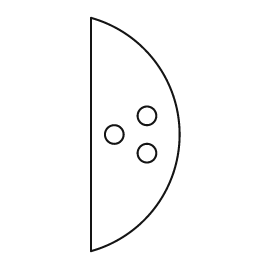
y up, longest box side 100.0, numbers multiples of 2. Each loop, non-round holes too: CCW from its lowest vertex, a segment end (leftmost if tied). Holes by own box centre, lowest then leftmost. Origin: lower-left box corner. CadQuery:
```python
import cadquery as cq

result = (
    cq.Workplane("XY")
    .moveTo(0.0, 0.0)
    .threePointArc((38.0, 50.0), (0.0, 100.0))
    .close()
    .moveTo(24.0, 42.0)
    .circle(4.0)
    .moveTo(10.0, 50.0)
    .circle(4.0)
    .moveTo(24.0, 58.0)
    .circle(4.0)
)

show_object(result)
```